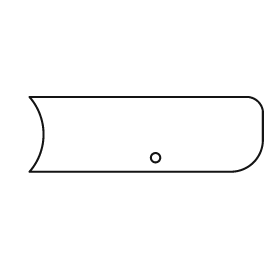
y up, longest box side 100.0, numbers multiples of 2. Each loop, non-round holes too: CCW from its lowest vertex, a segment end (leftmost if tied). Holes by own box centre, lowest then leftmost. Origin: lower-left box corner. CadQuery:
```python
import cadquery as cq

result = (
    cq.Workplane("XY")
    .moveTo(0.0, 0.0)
    .lineTo(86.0, 0.0)
    .threePointArc((96.0, 4.0), (100.0, 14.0))
    .lineTo(100.0, 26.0)
    .threePointArc((98.0, 30.0), (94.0, 32.0))
    .lineTo(0.0, 32.0)
    .threePointArc((6.0, 16.0), (0.0, 0.0))
    .close()
    .moveTo(54.0, 6.0)
    .circle(2.0)
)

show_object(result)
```